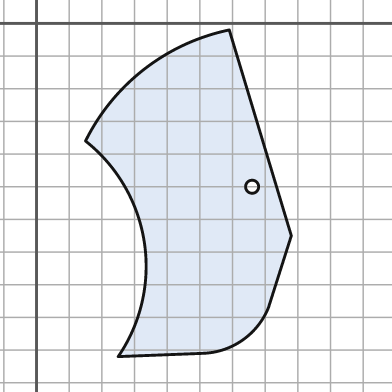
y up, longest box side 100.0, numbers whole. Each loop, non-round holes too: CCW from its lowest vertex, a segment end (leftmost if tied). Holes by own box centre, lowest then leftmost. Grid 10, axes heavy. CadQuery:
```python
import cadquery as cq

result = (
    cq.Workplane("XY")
    .moveTo(25.0, -102.0)
    .lineTo(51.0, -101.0)
    .threePointArc((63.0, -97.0), (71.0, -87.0))
    .lineTo(78.0, -65.0)
    .lineTo(59.0, -2.0)
    .threePointArc((33.0, -14.0), (15.0, -36.0))
    .threePointArc((33.0, -67.0), (25.0, -102.0))
    .close()
    .moveTo(66.0, -50.0)
    .circle(2.0)
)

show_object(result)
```